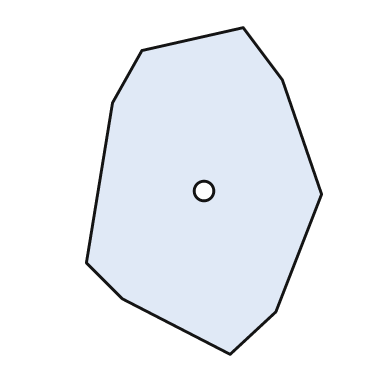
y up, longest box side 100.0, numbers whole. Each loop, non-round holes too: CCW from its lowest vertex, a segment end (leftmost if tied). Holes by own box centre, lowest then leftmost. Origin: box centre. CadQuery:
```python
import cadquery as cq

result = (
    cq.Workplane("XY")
    .moveTo(8.0, -50.0)
    .lineTo(22.0, -37.0)
    .lineTo(36.0, -1.0)
    .lineTo(24.0, 34.0)
    .lineTo(12.0, 50.0)
    .lineTo(-19.0, 43.0)
    .lineTo(-28.0, 27.0)
    .lineTo(-36.0, -22.0)
    .lineTo(-25.0, -33.0)
    .close()
    .moveTo(0.0, 0.0)
    .circle(3.0)
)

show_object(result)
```